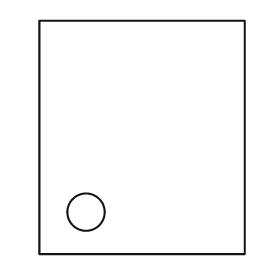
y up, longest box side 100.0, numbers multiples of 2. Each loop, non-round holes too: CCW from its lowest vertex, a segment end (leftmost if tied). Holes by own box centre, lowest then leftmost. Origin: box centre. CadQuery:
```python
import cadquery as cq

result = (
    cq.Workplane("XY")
    .moveTo(-44.0, -50.0)
    .lineTo(44.0, -50.0)
    .lineTo(44.0, 50.0)
    .lineTo(-44.0, 50.0)
    .close()
    .moveTo(-24.0, -32.0)
    .circle(8.0)
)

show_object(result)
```